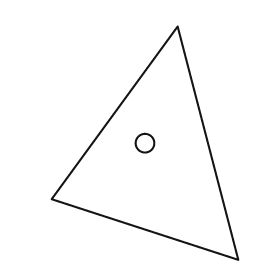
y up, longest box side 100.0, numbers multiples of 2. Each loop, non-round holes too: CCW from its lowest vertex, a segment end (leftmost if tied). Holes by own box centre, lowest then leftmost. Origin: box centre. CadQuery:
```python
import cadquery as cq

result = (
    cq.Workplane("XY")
    .moveTo(40.0, -50.0)
    .lineTo(14.0, 50.0)
    .lineTo(-40.0, -24.0)
    .close()
    .moveTo(0.0, 0.0)
    .circle(4.0)
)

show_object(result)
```